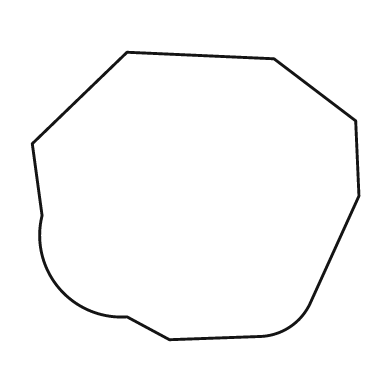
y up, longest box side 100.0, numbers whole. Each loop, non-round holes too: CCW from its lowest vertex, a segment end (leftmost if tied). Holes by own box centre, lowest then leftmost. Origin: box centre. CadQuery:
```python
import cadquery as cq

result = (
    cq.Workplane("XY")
    .moveTo(-8.0, -44.0)
    .lineTo(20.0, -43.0)
    .threePointArc((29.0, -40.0), (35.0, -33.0))
    .lineTo(50.0, 0.0)
    .lineTo(49.0, 23.0)
    .lineTo(24.0, 42.0)
    .lineTo(-21.0, 44.0)
    .lineTo(-50.0, 16.0)
    .lineTo(-47.0, -6.0)
    .threePointArc((-42.0, -28.0), (-21.0, -37.0))
    .close()
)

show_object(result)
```